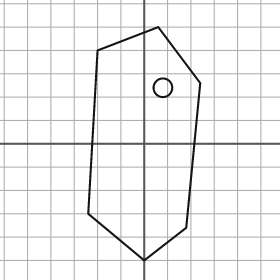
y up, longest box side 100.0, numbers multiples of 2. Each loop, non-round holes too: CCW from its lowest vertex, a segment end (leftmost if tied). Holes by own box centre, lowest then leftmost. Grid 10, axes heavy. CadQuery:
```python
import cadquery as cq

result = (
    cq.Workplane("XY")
    .moveTo(0.0, -50.0)
    .lineTo(18.0, -36.0)
    .lineTo(24.0, 26.0)
    .lineTo(6.0, 50.0)
    .lineTo(-20.0, 40.0)
    .lineTo(-24.0, -30.0)
    .close()
    .moveTo(8.0, 24.0)
    .circle(4.0)
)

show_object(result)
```